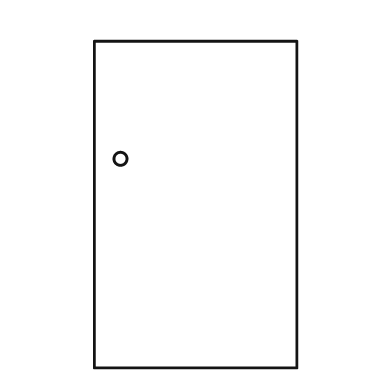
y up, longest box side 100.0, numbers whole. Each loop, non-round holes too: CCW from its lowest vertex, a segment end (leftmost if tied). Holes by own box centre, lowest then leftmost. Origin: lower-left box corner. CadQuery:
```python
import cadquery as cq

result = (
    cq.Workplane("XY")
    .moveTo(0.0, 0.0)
    .lineTo(62.0, 0.0)
    .lineTo(62.0, 100.0)
    .lineTo(0.0, 100.0)
    .close()
    .moveTo(8.0, 64.0)
    .circle(2.0)
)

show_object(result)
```